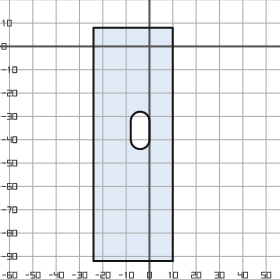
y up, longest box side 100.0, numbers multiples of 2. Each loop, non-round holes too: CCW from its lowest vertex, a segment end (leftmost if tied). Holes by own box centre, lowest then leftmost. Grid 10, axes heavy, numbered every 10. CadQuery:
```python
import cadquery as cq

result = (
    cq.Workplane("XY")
    .moveTo(-24.0, -92.0)
    .lineTo(10.0, -92.0)
    .lineTo(10.0, 8.0)
    .lineTo(-24.0, 8.0)
    .close()
    .moveTo(-8.0, -40.0)
    .threePointArc((-4.0, -44.0), (0.0, -40.0))
    .lineTo(0.0, -32.0)
    .threePointArc((-4.0, -28.0), (-8.0, -32.0))
    .close()
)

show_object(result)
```